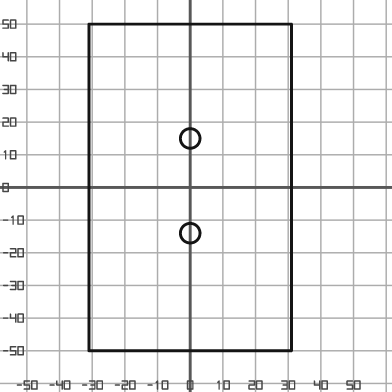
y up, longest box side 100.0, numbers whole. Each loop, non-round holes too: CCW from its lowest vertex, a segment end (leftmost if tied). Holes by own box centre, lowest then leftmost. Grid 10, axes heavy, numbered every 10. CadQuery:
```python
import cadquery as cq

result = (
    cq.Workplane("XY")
    .moveTo(-31.0, -50.0)
    .lineTo(31.0, -50.0)
    .lineTo(31.0, 50.0)
    .lineTo(-31.0, 50.0)
    .close()
    .moveTo(0.0, -14.0)
    .circle(3.0)
    .moveTo(0.0, 15.0)
    .circle(3.0)
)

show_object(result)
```